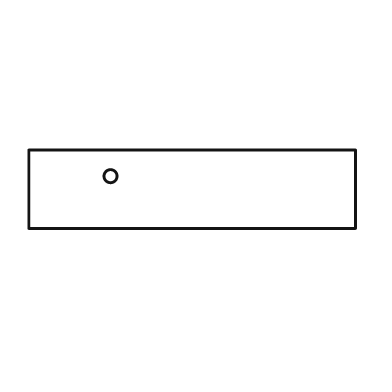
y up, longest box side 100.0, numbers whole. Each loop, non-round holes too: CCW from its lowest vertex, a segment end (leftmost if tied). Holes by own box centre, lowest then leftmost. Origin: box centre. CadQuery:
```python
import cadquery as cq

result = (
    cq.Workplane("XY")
    .moveTo(-50.0, -12.0)
    .lineTo(50.0, -12.0)
    .lineTo(50.0, 12.0)
    .lineTo(-50.0, 12.0)
    .close()
    .moveTo(-25.0, 4.0)
    .circle(2.0)
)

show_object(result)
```